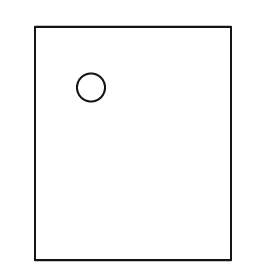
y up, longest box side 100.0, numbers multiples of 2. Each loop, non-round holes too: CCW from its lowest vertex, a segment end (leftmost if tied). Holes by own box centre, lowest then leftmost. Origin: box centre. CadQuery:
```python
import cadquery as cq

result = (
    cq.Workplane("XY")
    .moveTo(-42.0, -50.0)
    .lineTo(42.0, -50.0)
    .lineTo(42.0, 50.0)
    .lineTo(-42.0, 50.0)
    .close()
    .moveTo(-18.0, 24.0)
    .circle(6.0)
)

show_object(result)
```